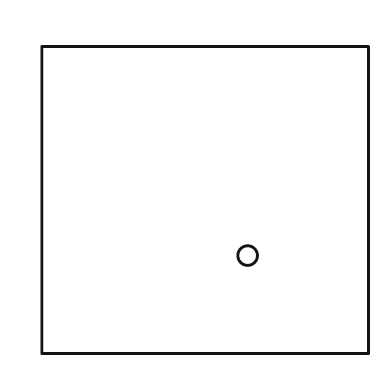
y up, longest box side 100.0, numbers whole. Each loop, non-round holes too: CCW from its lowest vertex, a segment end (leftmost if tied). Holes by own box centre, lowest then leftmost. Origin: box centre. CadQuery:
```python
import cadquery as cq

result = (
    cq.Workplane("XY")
    .moveTo(-50.0, -47.0)
    .lineTo(50.0, -47.0)
    .lineTo(50.0, 47.0)
    .lineTo(-50.0, 47.0)
    .close()
    .moveTo(13.0, -17.0)
    .circle(3.0)
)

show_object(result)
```